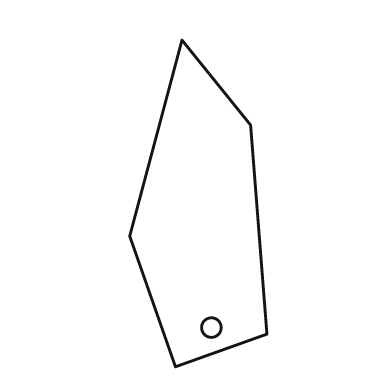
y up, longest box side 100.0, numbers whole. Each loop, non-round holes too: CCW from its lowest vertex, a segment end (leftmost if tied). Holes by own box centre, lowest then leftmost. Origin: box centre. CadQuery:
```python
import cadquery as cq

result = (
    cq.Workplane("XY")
    .moveTo(-7.0, -50.0)
    .lineTo(21.0, -40.0)
    .lineTo(16.0, 24.0)
    .lineTo(-5.0, 50.0)
    .lineTo(-21.0, -10.0)
    .close()
    .moveTo(4.0, -38.0)
    .circle(3.0)
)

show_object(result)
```